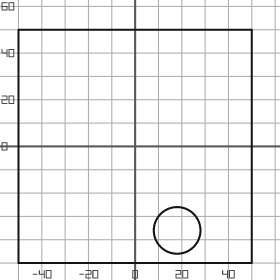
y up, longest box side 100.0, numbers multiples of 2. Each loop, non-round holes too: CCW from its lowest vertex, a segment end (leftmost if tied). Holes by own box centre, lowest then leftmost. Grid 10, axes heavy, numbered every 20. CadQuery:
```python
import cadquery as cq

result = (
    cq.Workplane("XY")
    .moveTo(-50.0, -50.0)
    .lineTo(50.0, -50.0)
    .lineTo(50.0, 50.0)
    .lineTo(-50.0, 50.0)
    .close()
    .moveTo(18.0, -36.0)
    .circle(10.0)
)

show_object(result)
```